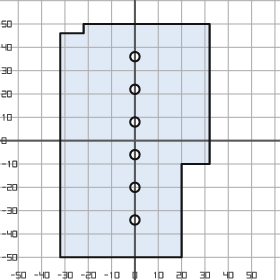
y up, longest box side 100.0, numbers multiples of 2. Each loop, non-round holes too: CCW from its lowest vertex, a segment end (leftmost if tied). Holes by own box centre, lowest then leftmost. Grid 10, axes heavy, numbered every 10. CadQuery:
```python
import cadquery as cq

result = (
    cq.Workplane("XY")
    .moveTo(-32.0, -50.0)
    .lineTo(20.0, -50.0)
    .lineTo(20.0, -10.0)
    .lineTo(32.0, -10.0)
    .lineTo(32.0, 50.0)
    .lineTo(-22.0, 50.0)
    .lineTo(-22.0, 46.0)
    .lineTo(-32.0, 46.0)
    .close()
    .moveTo(0.0, -34.0)
    .circle(2.0)
    .moveTo(0.0, -20.0)
    .circle(2.0)
    .moveTo(0.0, -6.0)
    .circle(2.0)
    .moveTo(0.0, 8.0)
    .circle(2.0)
    .moveTo(0.0, 22.0)
    .circle(2.0)
    .moveTo(0.0, 36.0)
    .circle(2.0)
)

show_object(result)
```